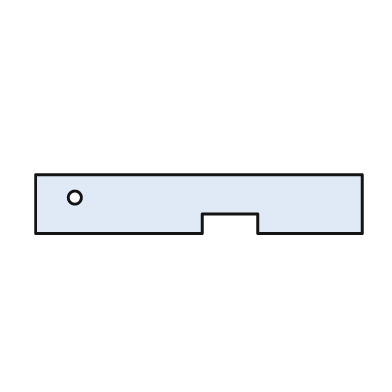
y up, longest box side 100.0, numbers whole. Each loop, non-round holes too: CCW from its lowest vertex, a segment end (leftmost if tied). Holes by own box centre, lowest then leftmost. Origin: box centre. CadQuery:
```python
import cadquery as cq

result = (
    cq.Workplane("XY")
    .moveTo(-50.0, -9.0)
    .lineTo(1.0, -9.0)
    .lineTo(1.0, -3.0)
    .lineTo(18.0, -3.0)
    .lineTo(18.0, -9.0)
    .lineTo(50.0, -9.0)
    .lineTo(50.0, 9.0)
    .lineTo(-50.0, 9.0)
    .close()
    .moveTo(-38.0, 2.0)
    .circle(2.0)
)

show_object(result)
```